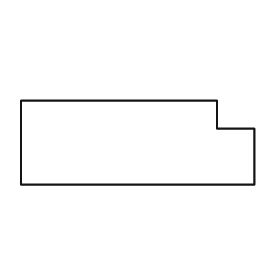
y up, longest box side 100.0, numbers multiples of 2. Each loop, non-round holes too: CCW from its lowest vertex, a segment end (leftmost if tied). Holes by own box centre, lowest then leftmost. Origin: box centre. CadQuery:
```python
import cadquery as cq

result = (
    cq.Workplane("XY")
    .moveTo(-50.0, -18.0)
    .lineTo(50.0, -18.0)
    .lineTo(50.0, 6.0)
    .lineTo(34.0, 6.0)
    .lineTo(34.0, 18.0)
    .lineTo(-50.0, 18.0)
    .close()
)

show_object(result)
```